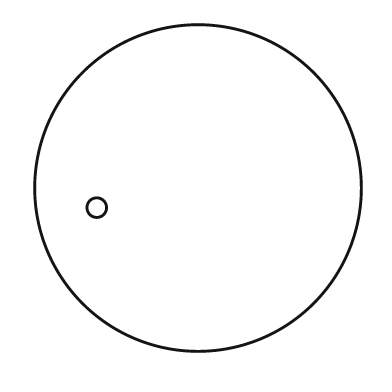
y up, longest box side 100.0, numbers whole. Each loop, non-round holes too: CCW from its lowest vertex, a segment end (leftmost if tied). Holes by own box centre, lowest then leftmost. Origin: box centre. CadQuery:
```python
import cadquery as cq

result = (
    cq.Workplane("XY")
    .moveTo(0.0, 0.0)
    .circle(50.0)
    .moveTo(-31.0, -6.0)
    .circle(3.0)
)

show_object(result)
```